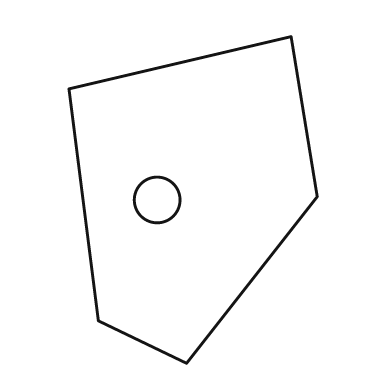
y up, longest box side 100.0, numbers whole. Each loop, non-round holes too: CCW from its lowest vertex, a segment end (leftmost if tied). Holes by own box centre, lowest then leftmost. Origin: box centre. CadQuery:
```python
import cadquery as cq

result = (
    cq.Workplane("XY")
    .moveTo(-2.0, -50.0)
    .lineTo(38.0, 1.0)
    .lineTo(30.0, 50.0)
    .lineTo(-38.0, 34.0)
    .lineTo(-29.0, -37.0)
    .close()
    .moveTo(-11.0, 0.0)
    .circle(7.0)
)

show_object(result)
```